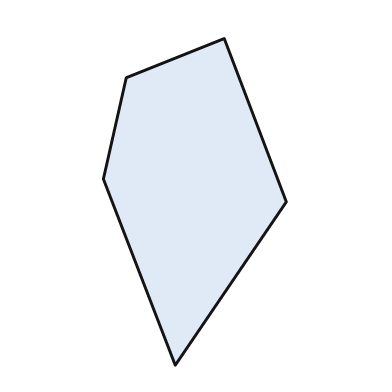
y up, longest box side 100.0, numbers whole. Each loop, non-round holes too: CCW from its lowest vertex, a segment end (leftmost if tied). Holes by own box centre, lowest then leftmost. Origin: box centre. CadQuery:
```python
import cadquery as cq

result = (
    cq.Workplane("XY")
    .moveTo(-6.0, -50.0)
    .lineTo(28.0, 0.0)
    .lineTo(9.0, 50.0)
    .lineTo(-21.0, 38.0)
    .lineTo(-28.0, 7.0)
    .close()
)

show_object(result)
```